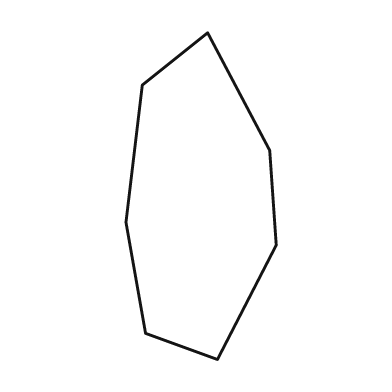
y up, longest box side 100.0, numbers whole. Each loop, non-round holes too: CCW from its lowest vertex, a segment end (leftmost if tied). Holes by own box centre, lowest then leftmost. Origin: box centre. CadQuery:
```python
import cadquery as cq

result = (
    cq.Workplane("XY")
    .moveTo(5.0, -50.0)
    .lineTo(23.0, -15.0)
    .lineTo(21.0, 14.0)
    .lineTo(2.0, 50.0)
    .lineTo(-18.0, 34.0)
    .lineTo(-23.0, -8.0)
    .lineTo(-17.0, -42.0)
    .close()
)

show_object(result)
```